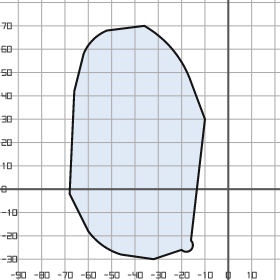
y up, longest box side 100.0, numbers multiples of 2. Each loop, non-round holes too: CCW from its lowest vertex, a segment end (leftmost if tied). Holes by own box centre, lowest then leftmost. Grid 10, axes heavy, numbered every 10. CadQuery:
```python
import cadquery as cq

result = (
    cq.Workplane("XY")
    .moveTo(-32.0, -30.0)
    .lineTo(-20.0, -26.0)
    .threePointArc((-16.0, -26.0), (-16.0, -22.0))
    .lineTo(-10.0, 30.0)
    .lineTo(-16.0, 46.0)
    .threePointArc((-24.0, 60.0), (-36.0, 70.0))
    .lineTo(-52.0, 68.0)
    .threePointArc((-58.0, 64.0), (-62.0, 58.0))
    .lineTo(-66.0, 42.0)
    .lineTo(-68.0, -2.0)
    .lineTo(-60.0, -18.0)
    .threePointArc((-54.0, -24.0), (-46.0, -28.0))
    .close()
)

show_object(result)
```